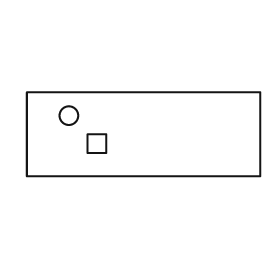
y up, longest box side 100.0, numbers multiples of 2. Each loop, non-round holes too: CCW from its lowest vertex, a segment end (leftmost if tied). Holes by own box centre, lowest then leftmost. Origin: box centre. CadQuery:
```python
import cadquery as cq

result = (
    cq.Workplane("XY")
    .moveTo(-50.0, -18.0)
    .lineTo(50.0, -18.0)
    .lineTo(50.0, 18.0)
    .lineTo(-50.0, 18.0)
    .close()
    .moveTo(-24.0, -8.0)
    .lineTo(-16.0, -8.0)
    .lineTo(-16.0, 0.0)
    .lineTo(-24.0, 0.0)
    .close()
    .moveTo(-32.0, 8.0)
    .circle(4.0)
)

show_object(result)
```